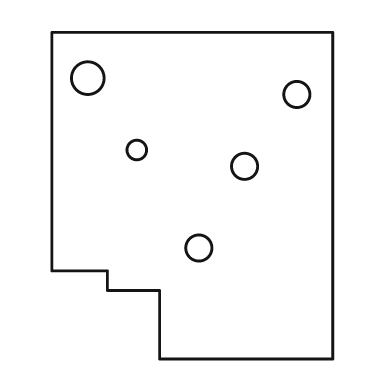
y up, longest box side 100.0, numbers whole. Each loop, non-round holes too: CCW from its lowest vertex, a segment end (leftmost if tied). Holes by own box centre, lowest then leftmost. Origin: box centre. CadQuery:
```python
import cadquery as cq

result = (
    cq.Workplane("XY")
    .moveTo(-10.0, -50.0)
    .lineTo(43.0, -50.0)
    .lineTo(43.0, 50.0)
    .lineTo(-43.0, 50.0)
    .lineTo(-43.0, -23.0)
    .lineTo(-26.0, -23.0)
    .lineTo(-26.0, -29.0)
    .lineTo(-10.0, -29.0)
    .close()
    .moveTo(2.0, -16.0)
    .circle(4.0)
    .moveTo(16.0, 9.0)
    .circle(4.0)
    .moveTo(-17.0, 14.0)
    .circle(3.0)
    .moveTo(32.0, 31.0)
    .circle(4.0)
    .moveTo(-32.0, 36.0)
    .circle(5.0)
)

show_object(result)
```